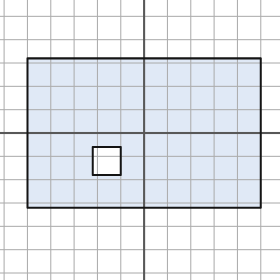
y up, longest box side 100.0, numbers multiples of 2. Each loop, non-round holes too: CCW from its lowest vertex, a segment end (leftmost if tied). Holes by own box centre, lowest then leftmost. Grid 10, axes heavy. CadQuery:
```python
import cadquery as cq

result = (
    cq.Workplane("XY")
    .moveTo(-50.0, -32.0)
    .lineTo(50.0, -32.0)
    .lineTo(50.0, 32.0)
    .lineTo(-50.0, 32.0)
    .close()
    .moveTo(-22.0, -18.0)
    .lineTo(-10.0, -18.0)
    .lineTo(-10.0, -6.0)
    .lineTo(-22.0, -6.0)
    .close()
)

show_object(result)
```